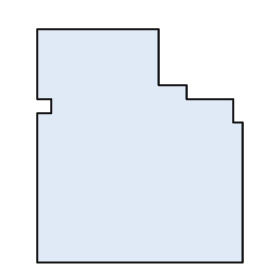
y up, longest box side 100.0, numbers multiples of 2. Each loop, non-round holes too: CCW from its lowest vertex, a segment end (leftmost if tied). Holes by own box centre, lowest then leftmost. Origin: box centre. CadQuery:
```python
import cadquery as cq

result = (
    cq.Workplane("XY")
    .moveTo(-44.0, -50.0)
    .lineTo(44.0, -50.0)
    .lineTo(44.0, 10.0)
    .lineTo(40.0, 10.0)
    .lineTo(40.0, 20.0)
    .lineTo(20.0, 20.0)
    .lineTo(20.0, 26.0)
    .lineTo(8.0, 26.0)
    .lineTo(8.0, 50.0)
    .lineTo(-44.0, 50.0)
    .lineTo(-44.0, 20.0)
    .lineTo(-38.0, 20.0)
    .lineTo(-38.0, 14.0)
    .lineTo(-44.0, 14.0)
    .close()
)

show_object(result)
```